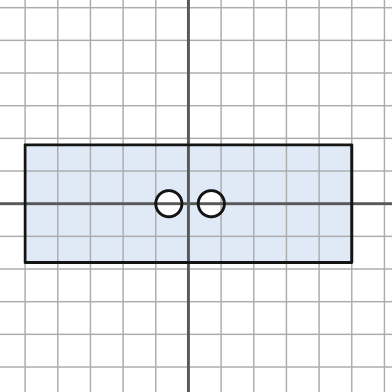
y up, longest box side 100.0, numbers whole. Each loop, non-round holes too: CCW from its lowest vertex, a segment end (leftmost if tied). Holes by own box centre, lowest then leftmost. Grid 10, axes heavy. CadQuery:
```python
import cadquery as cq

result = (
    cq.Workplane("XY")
    .moveTo(-50.0, -18.0)
    .lineTo(50.0, -18.0)
    .lineTo(50.0, 18.0)
    .lineTo(-50.0, 18.0)
    .close()
    .moveTo(-6.0, 0.0)
    .circle(4.0)
    .moveTo(7.0, 0.0)
    .circle(4.0)
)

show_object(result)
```